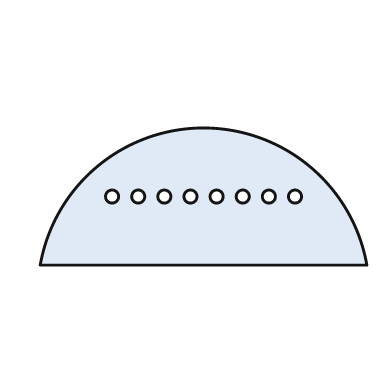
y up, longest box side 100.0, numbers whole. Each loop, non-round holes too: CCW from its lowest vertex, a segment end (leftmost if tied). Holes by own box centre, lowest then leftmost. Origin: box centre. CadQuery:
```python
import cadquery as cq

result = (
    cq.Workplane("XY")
    .moveTo(-50.0, -21.0)
    .lineTo(50.0, -21.0)
    .threePointArc((0.0, 21.0), (-50.0, -21.0))
    .close()
    .moveTo(-28.0, 0.0)
    .circle(2.0)
    .moveTo(-20.0, 0.0)
    .circle(2.0)
    .moveTo(-12.0, 0.0)
    .circle(2.0)
    .moveTo(-4.0, 0.0)
    .circle(2.0)
    .moveTo(4.0, 0.0)
    .circle(2.0)
    .moveTo(12.0, 0.0)
    .circle(2.0)
    .moveTo(20.0, 0.0)
    .circle(2.0)
    .moveTo(28.0, 0.0)
    .circle(2.0)
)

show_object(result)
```